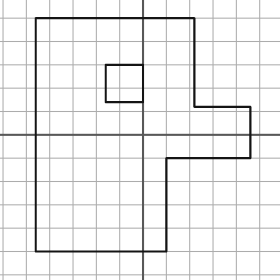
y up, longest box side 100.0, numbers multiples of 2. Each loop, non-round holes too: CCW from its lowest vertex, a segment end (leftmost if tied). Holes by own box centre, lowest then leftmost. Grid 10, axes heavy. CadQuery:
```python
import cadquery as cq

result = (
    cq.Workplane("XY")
    .moveTo(-46.0, -50.0)
    .lineTo(10.0, -50.0)
    .lineTo(10.0, -10.0)
    .lineTo(46.0, -10.0)
    .lineTo(46.0, 12.0)
    .lineTo(22.0, 12.0)
    .lineTo(22.0, 50.0)
    .lineTo(-46.0, 50.0)
    .close()
    .moveTo(-16.0, 14.0)
    .lineTo(0.0, 14.0)
    .lineTo(0.0, 30.0)
    .lineTo(-16.0, 30.0)
    .close()
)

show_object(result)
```